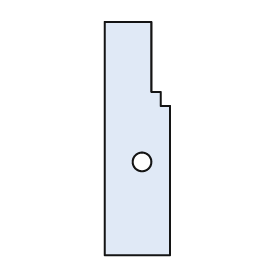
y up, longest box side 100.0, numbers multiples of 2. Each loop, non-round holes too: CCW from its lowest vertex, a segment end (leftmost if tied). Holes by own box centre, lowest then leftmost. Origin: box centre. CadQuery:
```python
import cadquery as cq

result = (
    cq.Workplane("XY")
    .moveTo(-14.0, -50.0)
    .lineTo(14.0, -50.0)
    .lineTo(14.0, 14.0)
    .lineTo(10.0, 14.0)
    .lineTo(10.0, 20.0)
    .lineTo(6.0, 20.0)
    .lineTo(6.0, 50.0)
    .lineTo(-14.0, 50.0)
    .close()
    .moveTo(2.0, -10.0)
    .circle(4.0)
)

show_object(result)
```